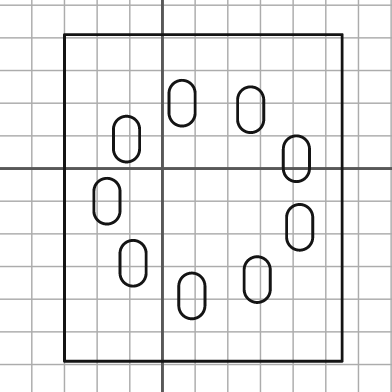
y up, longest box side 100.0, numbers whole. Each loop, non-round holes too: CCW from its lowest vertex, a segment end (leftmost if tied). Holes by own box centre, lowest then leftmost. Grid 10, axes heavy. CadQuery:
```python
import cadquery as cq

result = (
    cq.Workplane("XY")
    .moveTo(-30.0, -59.0)
    .lineTo(55.0, -59.0)
    .lineTo(55.0, 41.0)
    .lineTo(-30.0, 41.0)
    .close()
    .moveTo(5.0, -42.0)
    .threePointArc((9.0, -46.0), (13.0, -42.0))
    .lineTo(13.0, -36.0)
    .threePointArc((9.0, -32.0), (5.0, -36.0))
    .close()
    .moveTo(25.0, -37.0)
    .threePointArc((29.0, -41.0), (33.0, -37.0))
    .lineTo(33.0, -31.0)
    .threePointArc((29.0, -27.0), (25.0, -31.0))
    .close()
    .moveTo(-13.0, -32.0)
    .threePointArc((-9.0, -36.0), (-5.0, -32.0))
    .lineTo(-5.0, -26.0)
    .threePointArc((-9.0, -22.0), (-13.0, -26.0))
    .close()
    .moveTo(38.0, -21.0)
    .threePointArc((42.0, -25.0), (46.0, -21.0))
    .lineTo(46.0, -15.0)
    .threePointArc((42.0, -11.0), (38.0, -15.0))
    .close()
    .moveTo(-21.0, -13.0)
    .threePointArc((-17.0, -17.0), (-13.0, -13.0))
    .lineTo(-13.0, -7.0)
    .threePointArc((-17.0, -3.0), (-21.0, -7.0))
    .close()
    .moveTo(37.0, 0.0)
    .threePointArc((41.0, -4.0), (45.0, 0.0))
    .lineTo(45.0, 6.0)
    .threePointArc((41.0, 10.0), (37.0, 6.0))
    .close()
    .moveTo(-15.0, 6.0)
    .threePointArc((-11.0, 2.0), (-7.0, 6.0))
    .lineTo(-7.0, 12.0)
    .threePointArc((-11.0, 16.0), (-15.0, 12.0))
    .close()
    .moveTo(23.0, 15.0)
    .threePointArc((27.0, 11.0), (31.0, 15.0))
    .lineTo(31.0, 21.0)
    .threePointArc((27.0, 25.0), (23.0, 21.0))
    .close()
    .moveTo(2.0, 17.0)
    .threePointArc((6.0, 13.0), (10.0, 17.0))
    .lineTo(10.0, 23.0)
    .threePointArc((6.0, 27.0), (2.0, 23.0))
    .close()
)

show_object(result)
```